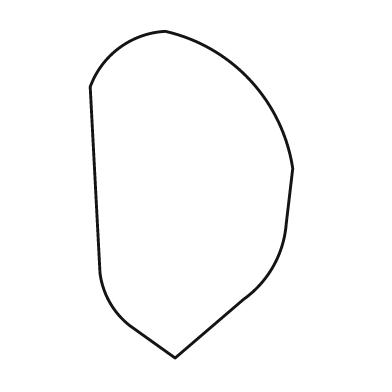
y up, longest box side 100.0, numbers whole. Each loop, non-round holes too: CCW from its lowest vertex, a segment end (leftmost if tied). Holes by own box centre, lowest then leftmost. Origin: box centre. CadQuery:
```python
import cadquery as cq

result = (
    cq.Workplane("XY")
    .moveTo(-5.0, -50.0)
    .lineTo(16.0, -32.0)
    .threePointArc((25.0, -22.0), (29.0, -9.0))
    .lineTo(31.0, 8.0)
    .threePointArc((18.0, 35.0), (-8.0, 50.0))
    .threePointArc((-22.0, 45.0), (-31.0, 33.0))
    .lineTo(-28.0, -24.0)
    .threePointArc((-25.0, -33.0), (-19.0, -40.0))
    .close()
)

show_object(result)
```